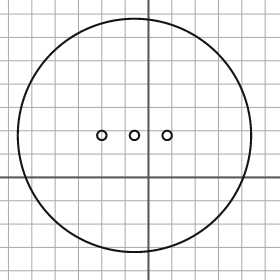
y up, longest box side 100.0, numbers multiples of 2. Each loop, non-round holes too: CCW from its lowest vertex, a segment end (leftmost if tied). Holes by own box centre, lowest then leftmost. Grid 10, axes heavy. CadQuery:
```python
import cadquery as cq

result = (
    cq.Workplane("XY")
    .moveTo(-6.0, 18.0)
    .circle(50.0)
    .moveTo(-20.0, 18.0)
    .circle(2.0)
    .moveTo(-6.0, 18.0)
    .circle(2.0)
    .moveTo(8.0, 18.0)
    .circle(2.0)
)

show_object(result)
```